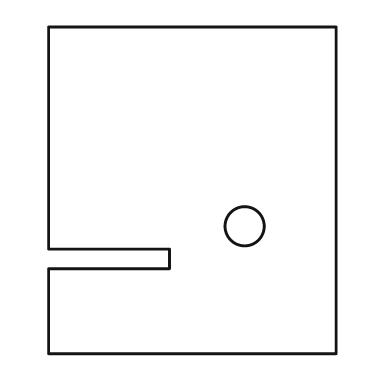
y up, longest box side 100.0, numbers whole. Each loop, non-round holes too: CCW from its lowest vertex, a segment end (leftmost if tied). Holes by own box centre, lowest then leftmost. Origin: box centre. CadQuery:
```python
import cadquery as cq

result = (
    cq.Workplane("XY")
    .moveTo(-44.0, -50.0)
    .lineTo(44.0, -50.0)
    .lineTo(44.0, 50.0)
    .lineTo(-44.0, 50.0)
    .lineTo(-44.0, -18.0)
    .lineTo(-7.0, -18.0)
    .lineTo(-7.0, -24.0)
    .lineTo(-44.0, -24.0)
    .close()
    .moveTo(16.0, -11.0)
    .circle(6.0)
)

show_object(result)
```